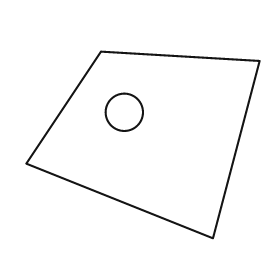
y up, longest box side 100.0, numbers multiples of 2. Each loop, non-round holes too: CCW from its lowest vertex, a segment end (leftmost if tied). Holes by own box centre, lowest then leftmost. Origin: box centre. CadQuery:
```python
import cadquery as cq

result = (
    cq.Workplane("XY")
    .moveTo(30.0, -40.0)
    .lineTo(50.0, 36.0)
    .lineTo(-18.0, 40.0)
    .lineTo(-50.0, -8.0)
    .close()
    .moveTo(-8.0, 14.0)
    .circle(8.0)
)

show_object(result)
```